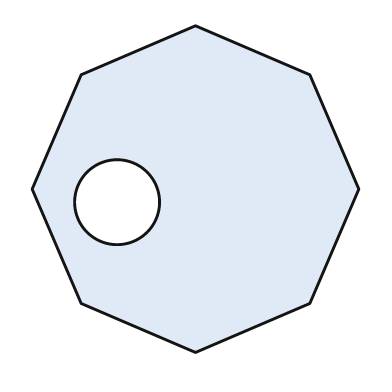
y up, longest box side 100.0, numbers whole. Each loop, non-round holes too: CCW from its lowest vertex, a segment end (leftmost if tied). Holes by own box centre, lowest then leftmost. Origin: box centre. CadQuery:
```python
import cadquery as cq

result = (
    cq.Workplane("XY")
    .moveTo(0.0, -50.0)
    .lineTo(35.0, -35.0)
    .lineTo(50.0, 0.0)
    .lineTo(35.0, 35.0)
    .lineTo(0.0, 50.0)
    .lineTo(-35.0, 35.0)
    .lineTo(-50.0, 0.0)
    .lineTo(-35.0, -35.0)
    .close()
    .moveTo(-24.0, -4.0)
    .circle(13.0)
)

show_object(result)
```